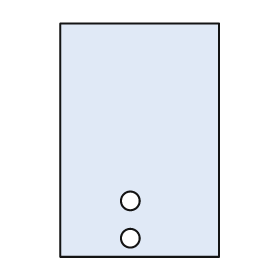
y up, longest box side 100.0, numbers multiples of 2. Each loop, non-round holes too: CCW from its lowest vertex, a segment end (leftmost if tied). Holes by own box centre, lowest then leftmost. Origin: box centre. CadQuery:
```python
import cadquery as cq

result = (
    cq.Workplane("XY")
    .moveTo(-34.0, -50.0)
    .lineTo(34.0, -50.0)
    .lineTo(34.0, 50.0)
    .lineTo(-34.0, 50.0)
    .close()
    .moveTo(-4.0, -42.0)
    .circle(4.0)
    .moveTo(-4.0, -26.0)
    .circle(4.0)
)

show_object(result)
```